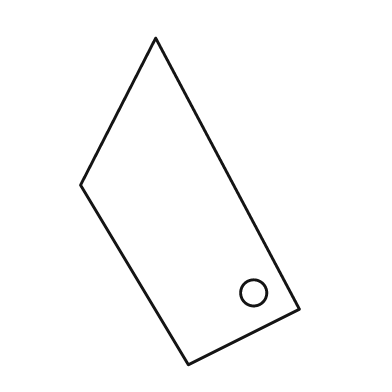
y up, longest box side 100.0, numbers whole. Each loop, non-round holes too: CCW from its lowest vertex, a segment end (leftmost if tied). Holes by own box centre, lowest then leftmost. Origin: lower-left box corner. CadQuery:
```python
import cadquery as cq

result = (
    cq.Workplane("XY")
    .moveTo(33.0, 0.0)
    .lineTo(67.0, 17.0)
    .lineTo(23.0, 100.0)
    .lineTo(0.0, 55.0)
    .close()
    .moveTo(53.0, 22.0)
    .circle(4.0)
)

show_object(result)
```